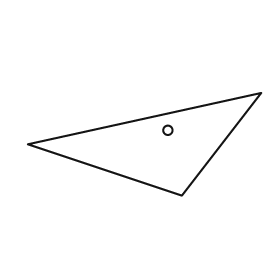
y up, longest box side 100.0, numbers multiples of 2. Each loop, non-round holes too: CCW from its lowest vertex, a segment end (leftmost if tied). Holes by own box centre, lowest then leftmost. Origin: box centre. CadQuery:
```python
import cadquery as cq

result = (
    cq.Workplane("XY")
    .moveTo(16.0, -22.0)
    .lineTo(50.0, 22.0)
    .lineTo(-50.0, 0.0)
    .close()
    .moveTo(10.0, 6.0)
    .circle(2.0)
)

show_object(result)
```